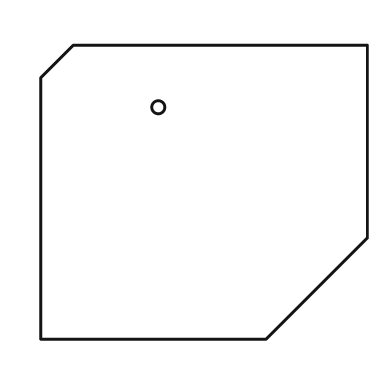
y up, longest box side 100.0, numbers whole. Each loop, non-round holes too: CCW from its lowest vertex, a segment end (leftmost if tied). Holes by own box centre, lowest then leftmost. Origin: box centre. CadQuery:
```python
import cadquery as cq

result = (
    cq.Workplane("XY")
    .moveTo(-50.0, -45.0)
    .lineTo(19.0, -45.0)
    .lineTo(50.0, -14.0)
    .lineTo(50.0, 45.0)
    .lineTo(-40.0, 45.0)
    .lineTo(-50.0, 35.0)
    .close()
    .moveTo(-14.0, 26.0)
    .circle(2.0)
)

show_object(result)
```